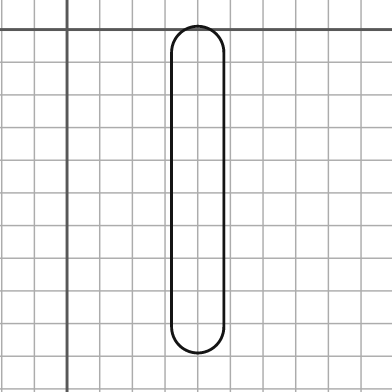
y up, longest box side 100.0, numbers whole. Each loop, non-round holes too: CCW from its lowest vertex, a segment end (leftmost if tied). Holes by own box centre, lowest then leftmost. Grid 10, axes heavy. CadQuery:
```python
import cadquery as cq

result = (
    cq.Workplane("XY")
    .moveTo(32.0, -91.0)
    .threePointArc((40.0, -99.0), (48.0, -91.0))
    .lineTo(48.0, -7.0)
    .threePointArc((40.0, 1.0), (32.0, -7.0))
    .close()
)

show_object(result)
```